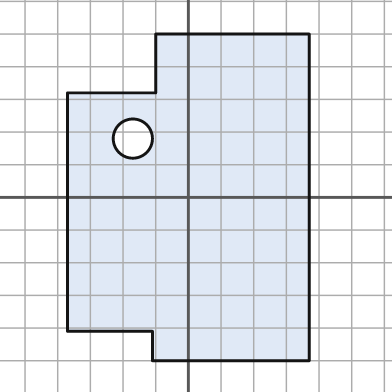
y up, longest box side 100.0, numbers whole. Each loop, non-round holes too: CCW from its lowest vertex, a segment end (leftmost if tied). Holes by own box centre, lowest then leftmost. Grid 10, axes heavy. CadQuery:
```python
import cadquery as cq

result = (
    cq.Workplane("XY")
    .moveTo(-11.0, -50.0)
    .lineTo(37.0, -50.0)
    .lineTo(37.0, 50.0)
    .lineTo(-10.0, 50.0)
    .lineTo(-10.0, 32.0)
    .lineTo(-37.0, 32.0)
    .lineTo(-37.0, -41.0)
    .lineTo(-11.0, -41.0)
    .close()
    .moveTo(-17.0, 18.0)
    .circle(6.0)
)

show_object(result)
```